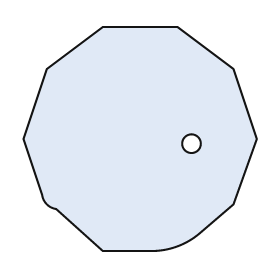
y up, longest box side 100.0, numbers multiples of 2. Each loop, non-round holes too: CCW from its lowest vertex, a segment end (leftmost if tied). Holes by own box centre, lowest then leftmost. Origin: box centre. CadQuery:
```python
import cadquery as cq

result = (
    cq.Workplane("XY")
    .moveTo(-16.0, -48.0)
    .lineTo(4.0, -48.0)
    .threePointArc((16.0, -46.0), (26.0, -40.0))
    .lineTo(40.0, -28.0)
    .lineTo(50.0, 0.0)
    .lineTo(40.0, 30.0)
    .lineTo(16.0, 48.0)
    .lineTo(-16.0, 48.0)
    .lineTo(-40.0, 30.0)
    .lineTo(-50.0, 0.0)
    .lineTo(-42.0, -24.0)
    .threePointArc((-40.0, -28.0), (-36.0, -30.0))
    .close()
    .moveTo(22.0, -2.0)
    .circle(4.0)
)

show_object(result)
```